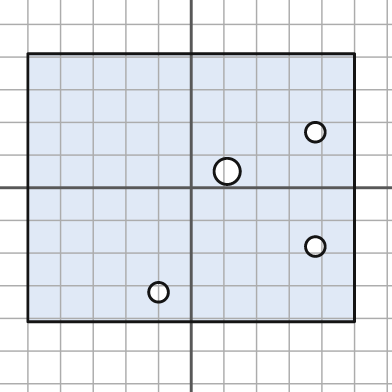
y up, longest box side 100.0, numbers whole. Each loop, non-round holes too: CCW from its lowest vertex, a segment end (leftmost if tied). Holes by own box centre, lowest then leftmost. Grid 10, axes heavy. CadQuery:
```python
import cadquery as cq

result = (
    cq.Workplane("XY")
    .moveTo(-50.0, -41.0)
    .lineTo(50.0, -41.0)
    .lineTo(50.0, 41.0)
    .lineTo(-50.0, 41.0)
    .close()
    .moveTo(-10.0, -32.0)
    .circle(3.0)
    .moveTo(38.0, -18.0)
    .circle(3.0)
    .moveTo(11.0, 5.0)
    .circle(4.0)
    .moveTo(38.0, 17.0)
    .circle(3.0)
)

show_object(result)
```